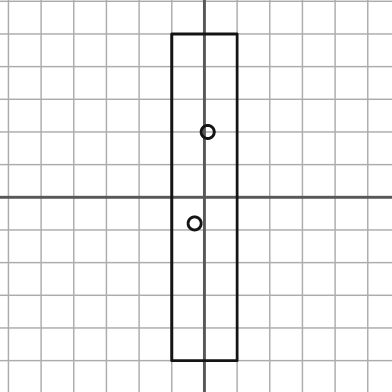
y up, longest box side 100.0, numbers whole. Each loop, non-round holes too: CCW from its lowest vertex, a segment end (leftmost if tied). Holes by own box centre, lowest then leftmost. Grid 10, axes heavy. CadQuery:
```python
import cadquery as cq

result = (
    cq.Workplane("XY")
    .moveTo(-10.0, -50.0)
    .lineTo(10.0, -50.0)
    .lineTo(10.0, 50.0)
    .lineTo(-10.0, 50.0)
    .close()
    .moveTo(-3.0, -8.0)
    .circle(2.0)
    .moveTo(1.0, 20.0)
    .circle(2.0)
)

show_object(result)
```